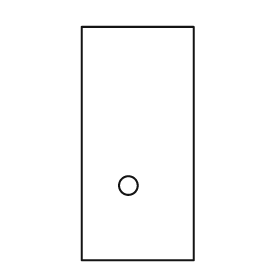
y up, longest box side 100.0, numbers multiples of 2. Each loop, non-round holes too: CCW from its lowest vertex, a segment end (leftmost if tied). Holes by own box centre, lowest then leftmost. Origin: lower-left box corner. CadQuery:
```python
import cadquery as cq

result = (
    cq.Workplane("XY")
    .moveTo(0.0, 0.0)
    .lineTo(48.0, 0.0)
    .lineTo(48.0, 100.0)
    .lineTo(0.0, 100.0)
    .close()
    .moveTo(20.0, 32.0)
    .circle(4.0)
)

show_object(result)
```